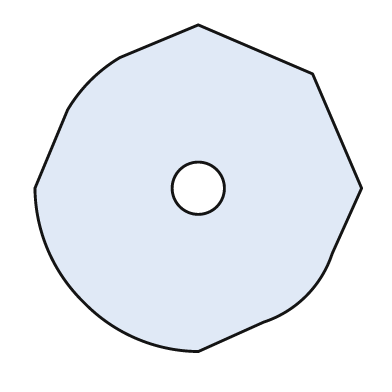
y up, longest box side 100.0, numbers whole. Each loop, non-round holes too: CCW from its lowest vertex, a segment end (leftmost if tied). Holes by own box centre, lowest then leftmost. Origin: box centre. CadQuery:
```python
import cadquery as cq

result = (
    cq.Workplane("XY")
    .moveTo(0.0, -50.0)
    .lineTo(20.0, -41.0)
    .threePointArc((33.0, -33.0), (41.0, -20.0))
    .lineTo(50.0, 0.0)
    .lineTo(35.0, 35.0)
    .lineTo(0.0, 50.0)
    .lineTo(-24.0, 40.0)
    .threePointArc((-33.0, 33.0), (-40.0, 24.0))
    .lineTo(-50.0, 0.0)
    .threePointArc((-46.0, -19.0), (-35.0, -35.0))
    .threePointArc((-19.0, -46.0), (0.0, -50.0))
    .close()
    .moveTo(0.0, 0.0)
    .circle(8.0)
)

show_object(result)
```